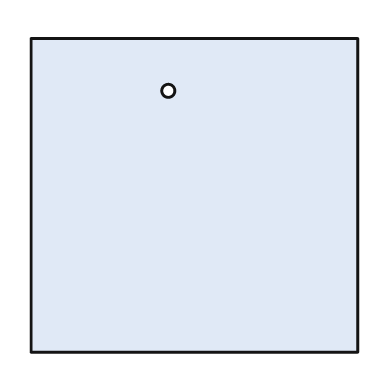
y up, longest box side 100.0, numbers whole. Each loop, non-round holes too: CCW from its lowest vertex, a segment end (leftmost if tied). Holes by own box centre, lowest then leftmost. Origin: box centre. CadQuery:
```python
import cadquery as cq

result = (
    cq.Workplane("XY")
    .moveTo(-50.0, -48.0)
    .lineTo(50.0, -48.0)
    .lineTo(50.0, 48.0)
    .lineTo(-50.0, 48.0)
    .close()
    .moveTo(-8.0, 32.0)
    .circle(2.0)
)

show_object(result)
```